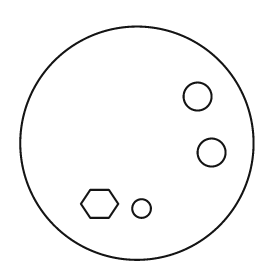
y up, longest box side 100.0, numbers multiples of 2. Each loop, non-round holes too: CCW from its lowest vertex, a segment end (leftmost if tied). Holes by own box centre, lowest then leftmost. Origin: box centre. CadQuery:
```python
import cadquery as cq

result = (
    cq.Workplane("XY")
    .moveTo(0.0, 0.0)
    .circle(50.0)
    .moveTo(2.0, -28.0)
    .circle(4.0)
    .moveTo(-20.0, -32.0)
    .lineTo(-12.0, -32.0)
    .lineTo(-8.0, -26.0)
    .lineTo(-12.0, -20.0)
    .lineTo(-20.0, -20.0)
    .lineTo(-24.0, -26.0)
    .close()
    .moveTo(32.0, -4.0)
    .circle(6.0)
    .moveTo(26.0, 20.0)
    .circle(6.0)
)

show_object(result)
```